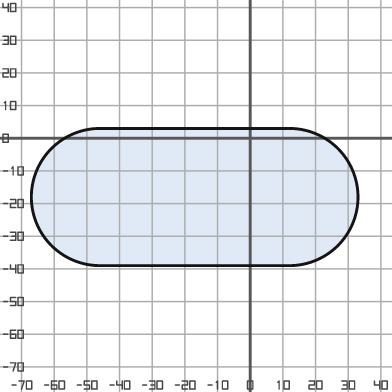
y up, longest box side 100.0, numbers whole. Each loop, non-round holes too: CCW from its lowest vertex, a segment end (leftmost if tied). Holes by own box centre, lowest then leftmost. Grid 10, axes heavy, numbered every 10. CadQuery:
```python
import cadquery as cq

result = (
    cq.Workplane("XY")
    .moveTo(-46.0, -39.0)
    .lineTo(12.0, -39.0)
    .threePointArc((33.0, -18.0), (12.0, 3.0))
    .lineTo(-46.0, 3.0)
    .threePointArc((-67.0, -18.0), (-46.0, -39.0))
    .close()
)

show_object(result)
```